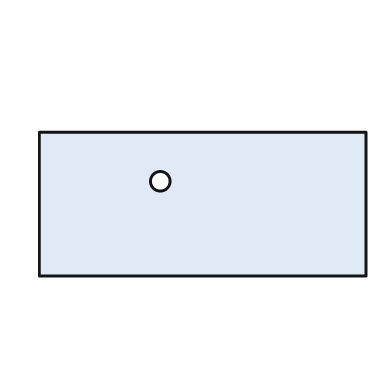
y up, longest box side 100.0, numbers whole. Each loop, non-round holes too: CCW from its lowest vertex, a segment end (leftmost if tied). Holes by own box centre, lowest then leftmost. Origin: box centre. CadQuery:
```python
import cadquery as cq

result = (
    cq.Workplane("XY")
    .moveTo(-50.0, -22.0)
    .lineTo(50.0, -22.0)
    .lineTo(50.0, 22.0)
    .lineTo(-50.0, 22.0)
    .close()
    .moveTo(-13.0, 7.0)
    .circle(3.0)
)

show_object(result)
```